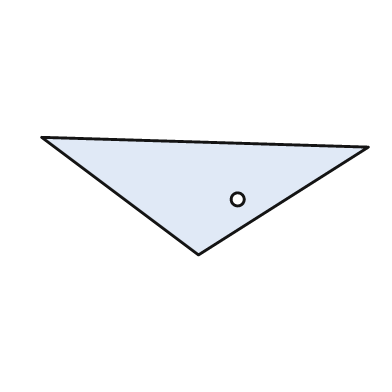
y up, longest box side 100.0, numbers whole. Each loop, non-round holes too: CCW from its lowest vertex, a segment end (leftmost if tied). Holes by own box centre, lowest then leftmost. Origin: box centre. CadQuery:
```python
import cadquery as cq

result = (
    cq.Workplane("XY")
    .moveTo(-2.0, -18.0)
    .lineTo(50.0, 15.0)
    .lineTo(-50.0, 18.0)
    .close()
    .moveTo(10.0, -1.0)
    .circle(2.0)
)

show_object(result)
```